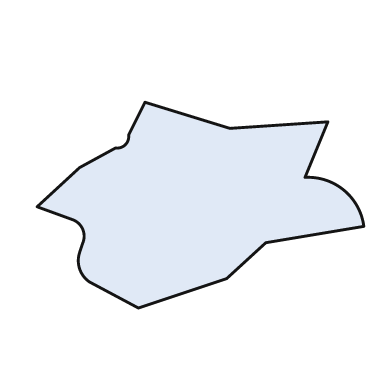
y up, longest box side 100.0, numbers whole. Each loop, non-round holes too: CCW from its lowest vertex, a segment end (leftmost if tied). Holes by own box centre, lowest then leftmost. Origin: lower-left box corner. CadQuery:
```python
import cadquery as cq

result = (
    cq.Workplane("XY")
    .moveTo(31.0, 0.0)
    .lineTo(58.0, 9.0)
    .lineTo(70.0, 20.0)
    .lineTo(100.0, 25.0)
    .threePointArc((94.0, 36.0), (82.0, 40.0))
    .lineTo(89.0, 57.0)
    .lineTo(59.0, 55.0)
    .lineTo(33.0, 63.0)
    .lineTo(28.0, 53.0)
    .threePointArc((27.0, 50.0), (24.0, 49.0))
    .lineTo(13.0, 43.0)
    .lineTo(0.0, 31.0)
    .lineTo(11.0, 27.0)
    .threePointArc((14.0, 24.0), (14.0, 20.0))
    .lineTo(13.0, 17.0)
    .threePointArc((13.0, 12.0), (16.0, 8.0))
    .close()
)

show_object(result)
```